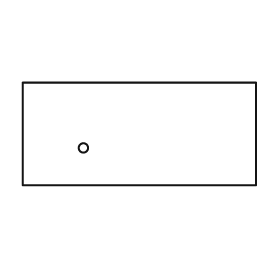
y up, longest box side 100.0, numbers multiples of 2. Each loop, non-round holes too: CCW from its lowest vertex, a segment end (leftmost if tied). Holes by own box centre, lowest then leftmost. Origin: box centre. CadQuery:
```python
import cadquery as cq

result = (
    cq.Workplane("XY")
    .moveTo(-50.0, -22.0)
    .lineTo(50.0, -22.0)
    .lineTo(50.0, 22.0)
    .lineTo(-50.0, 22.0)
    .close()
    .moveTo(-24.0, -6.0)
    .circle(2.0)
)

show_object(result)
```